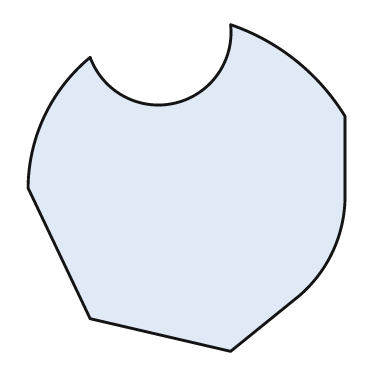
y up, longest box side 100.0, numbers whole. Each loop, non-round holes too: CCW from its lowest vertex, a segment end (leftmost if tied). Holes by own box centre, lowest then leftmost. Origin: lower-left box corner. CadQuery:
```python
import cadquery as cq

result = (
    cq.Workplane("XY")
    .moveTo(62.0, 0.0)
    .lineTo(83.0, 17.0)
    .threePointArc((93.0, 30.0), (97.0, 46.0))
    .lineTo(97.0, 72.0)
    .threePointArc((82.0, 89.0), (62.0, 100.0))
    .threePointArc((45.0, 76.0), (19.0, 90.0))
    .threePointArc((5.0, 72.0), (0.0, 50.0))
    .lineTo(19.0, 10.0)
    .close()
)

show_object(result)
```